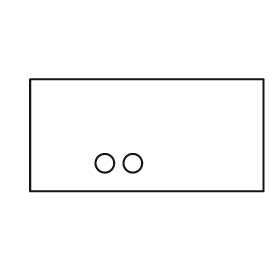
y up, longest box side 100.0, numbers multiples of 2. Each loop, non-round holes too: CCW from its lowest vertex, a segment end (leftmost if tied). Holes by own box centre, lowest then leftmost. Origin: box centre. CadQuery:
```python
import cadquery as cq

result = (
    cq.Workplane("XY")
    .moveTo(-50.0, -24.0)
    .lineTo(50.0, -24.0)
    .lineTo(50.0, 24.0)
    .lineTo(-50.0, 24.0)
    .close()
    .moveTo(-18.0, -12.0)
    .circle(4.0)
    .moveTo(-6.0, -12.0)
    .circle(4.0)
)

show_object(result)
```